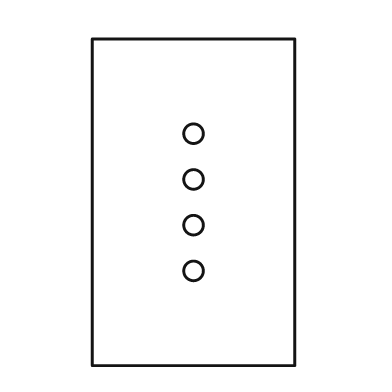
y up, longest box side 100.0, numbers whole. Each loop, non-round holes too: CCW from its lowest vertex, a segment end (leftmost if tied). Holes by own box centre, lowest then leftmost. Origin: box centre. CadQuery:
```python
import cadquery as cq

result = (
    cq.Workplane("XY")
    .moveTo(-31.0, -50.0)
    .lineTo(31.0, -50.0)
    .lineTo(31.0, 50.0)
    .lineTo(-31.0, 50.0)
    .close()
    .moveTo(0.0, -21.0)
    .circle(3.0)
    .moveTo(0.0, -7.0)
    .circle(3.0)
    .moveTo(0.0, 7.0)
    .circle(3.0)
    .moveTo(0.0, 21.0)
    .circle(3.0)
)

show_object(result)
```